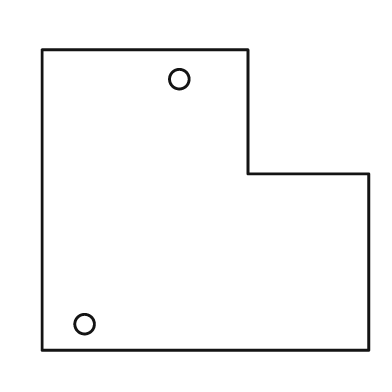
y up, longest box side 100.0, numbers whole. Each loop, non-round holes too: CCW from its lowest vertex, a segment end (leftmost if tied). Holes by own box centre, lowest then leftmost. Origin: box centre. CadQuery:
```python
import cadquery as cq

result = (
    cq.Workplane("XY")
    .moveTo(-50.0, -46.0)
    .lineTo(50.0, -46.0)
    .lineTo(50.0, 8.0)
    .lineTo(13.0, 8.0)
    .lineTo(13.0, 46.0)
    .lineTo(-50.0, 46.0)
    .close()
    .moveTo(-37.0, -38.0)
    .circle(3.0)
    .moveTo(-8.0, 37.0)
    .circle(3.0)
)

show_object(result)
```